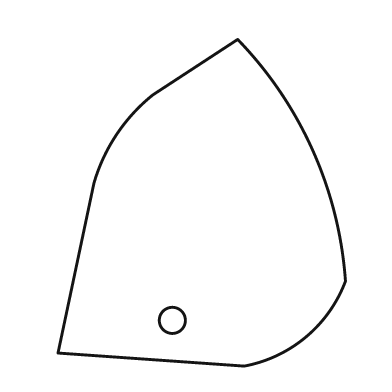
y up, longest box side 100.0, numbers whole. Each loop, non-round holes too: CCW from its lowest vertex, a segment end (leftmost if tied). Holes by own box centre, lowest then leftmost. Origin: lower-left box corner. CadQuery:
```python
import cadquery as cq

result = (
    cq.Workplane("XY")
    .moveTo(57.0, 0.0)
    .threePointArc((76.0, 9.0), (88.0, 26.0))
    .threePointArc((78.0, 66.0), (55.0, 100.0))
    .lineTo(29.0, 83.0)
    .threePointArc((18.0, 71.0), (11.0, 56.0))
    .lineTo(0.0, 4.0)
    .close()
    .moveTo(35.0, 14.0)
    .circle(4.0)
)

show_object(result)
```